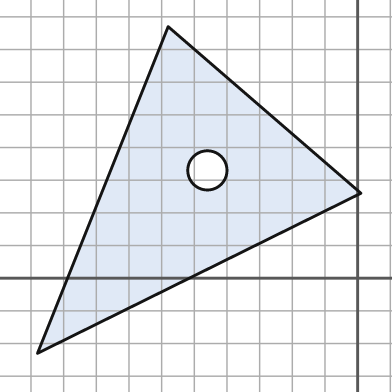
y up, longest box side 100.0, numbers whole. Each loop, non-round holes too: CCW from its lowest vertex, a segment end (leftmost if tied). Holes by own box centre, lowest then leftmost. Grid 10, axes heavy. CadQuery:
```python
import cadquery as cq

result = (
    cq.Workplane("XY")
    .moveTo(-98.0, -23.0)
    .lineTo(1.0, 26.0)
    .lineTo(-58.0, 77.0)
    .close()
    .moveTo(-46.0, 33.0)
    .circle(6.0)
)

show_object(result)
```